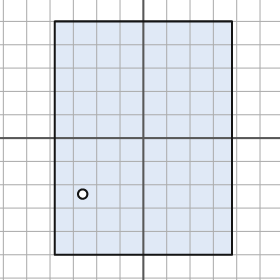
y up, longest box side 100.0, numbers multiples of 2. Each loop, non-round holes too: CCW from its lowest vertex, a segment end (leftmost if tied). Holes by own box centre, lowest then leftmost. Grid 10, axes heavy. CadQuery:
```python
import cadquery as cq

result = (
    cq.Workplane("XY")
    .moveTo(-38.0, -50.0)
    .lineTo(38.0, -50.0)
    .lineTo(38.0, 50.0)
    .lineTo(-38.0, 50.0)
    .close()
    .moveTo(-26.0, -24.0)
    .circle(2.0)
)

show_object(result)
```